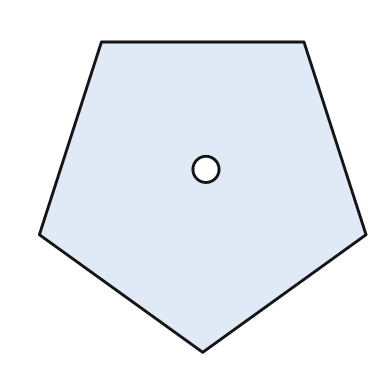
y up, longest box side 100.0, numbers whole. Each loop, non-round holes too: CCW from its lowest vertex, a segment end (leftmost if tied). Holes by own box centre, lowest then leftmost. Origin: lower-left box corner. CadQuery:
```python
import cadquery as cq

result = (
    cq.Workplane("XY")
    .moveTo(50.0, 0.0)
    .lineTo(100.0, 36.0)
    .lineTo(81.0, 95.0)
    .lineTo(19.0, 95.0)
    .lineTo(0.0, 36.0)
    .close()
    .moveTo(51.0, 56.0)
    .circle(4.0)
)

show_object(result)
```